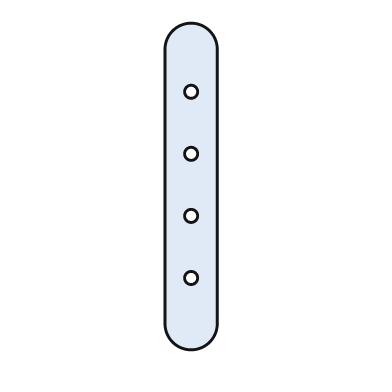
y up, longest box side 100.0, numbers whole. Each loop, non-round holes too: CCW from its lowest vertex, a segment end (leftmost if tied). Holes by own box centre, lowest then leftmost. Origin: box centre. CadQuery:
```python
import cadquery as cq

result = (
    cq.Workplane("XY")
    .moveTo(-8.0, -42.0)
    .threePointArc((0.0, -50.0), (8.0, -42.0))
    .lineTo(8.0, 42.0)
    .threePointArc((0.0, 50.0), (-8.0, 42.0))
    .close()
    .moveTo(0.0, -28.0)
    .circle(2.0)
    .moveTo(0.0, -9.0)
    .circle(2.0)
    .moveTo(0.0, 10.0)
    .circle(2.0)
    .moveTo(0.0, 29.0)
    .circle(2.0)
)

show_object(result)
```